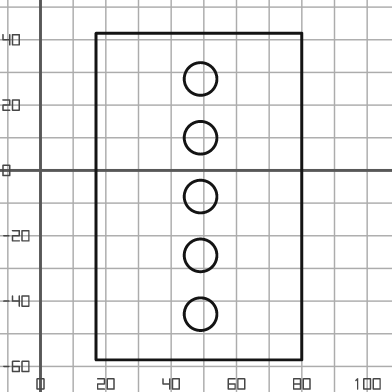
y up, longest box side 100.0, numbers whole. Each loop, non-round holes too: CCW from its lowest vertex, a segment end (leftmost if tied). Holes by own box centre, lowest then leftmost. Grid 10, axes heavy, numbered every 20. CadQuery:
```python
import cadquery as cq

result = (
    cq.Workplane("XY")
    .moveTo(17.0, -58.0)
    .lineTo(80.0, -58.0)
    .lineTo(80.0, 42.0)
    .lineTo(17.0, 42.0)
    .close()
    .moveTo(49.0, -44.0)
    .circle(5.0)
    .moveTo(49.0, -26.0)
    .circle(5.0)
    .moveTo(49.0, -8.0)
    .circle(5.0)
    .moveTo(49.0, 10.0)
    .circle(5.0)
    .moveTo(49.0, 28.0)
    .circle(5.0)
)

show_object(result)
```